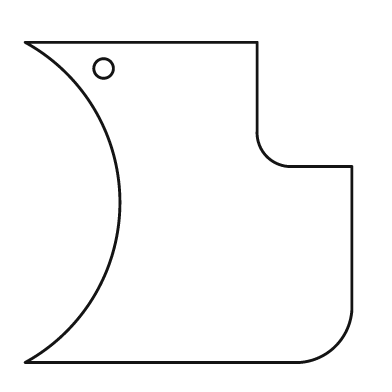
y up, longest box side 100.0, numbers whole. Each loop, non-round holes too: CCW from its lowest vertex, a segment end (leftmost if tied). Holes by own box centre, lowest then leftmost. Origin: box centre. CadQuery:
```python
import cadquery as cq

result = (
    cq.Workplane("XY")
    .moveTo(-50.0, -49.0)
    .lineTo(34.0, -49.0)
    .threePointArc((45.0, -44.0), (50.0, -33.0))
    .lineTo(50.0, 11.0)
    .lineTo(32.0, 11.0)
    .threePointArc((24.0, 14.0), (21.0, 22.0))
    .lineTo(21.0, 49.0)
    .lineTo(-50.0, 49.0)
    .threePointArc((-21.0, 0.0), (-50.0, -49.0))
    .close()
    .moveTo(-26.0, 41.0)
    .circle(3.0)
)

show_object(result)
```